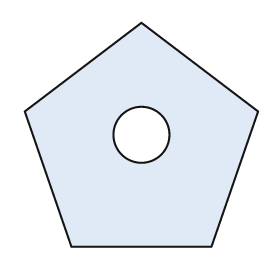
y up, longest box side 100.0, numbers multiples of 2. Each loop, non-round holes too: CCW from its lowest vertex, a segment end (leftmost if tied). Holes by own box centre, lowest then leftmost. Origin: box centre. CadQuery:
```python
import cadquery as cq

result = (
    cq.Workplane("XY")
    .moveTo(-30.0, -48.0)
    .lineTo(30.0, -48.0)
    .lineTo(50.0, 10.0)
    .lineTo(0.0, 48.0)
    .lineTo(-50.0, 10.0)
    .close()
    .moveTo(0.0, 0.0)
    .circle(12.0)
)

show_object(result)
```